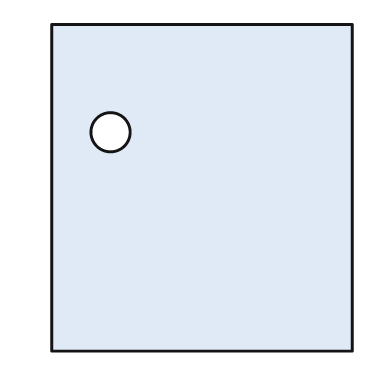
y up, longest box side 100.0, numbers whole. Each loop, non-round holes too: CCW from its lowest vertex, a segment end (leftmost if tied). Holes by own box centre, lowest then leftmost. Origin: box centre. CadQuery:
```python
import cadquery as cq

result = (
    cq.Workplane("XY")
    .moveTo(-46.0, -50.0)
    .lineTo(46.0, -50.0)
    .lineTo(46.0, 50.0)
    .lineTo(-46.0, 50.0)
    .close()
    .moveTo(-28.0, 17.0)
    .circle(6.0)
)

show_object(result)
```